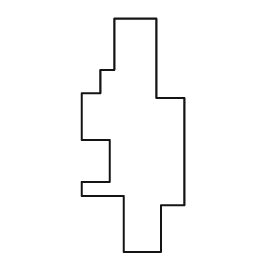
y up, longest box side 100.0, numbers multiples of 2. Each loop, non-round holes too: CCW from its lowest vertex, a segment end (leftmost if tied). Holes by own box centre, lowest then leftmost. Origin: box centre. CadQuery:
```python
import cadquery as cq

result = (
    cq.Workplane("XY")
    .moveTo(-4.0, -50.0)
    .lineTo(12.0, -50.0)
    .lineTo(12.0, -30.0)
    .lineTo(22.0, -30.0)
    .lineTo(22.0, 16.0)
    .lineTo(10.0, 16.0)
    .lineTo(10.0, 50.0)
    .lineTo(-8.0, 50.0)
    .lineTo(-8.0, 28.0)
    .lineTo(-14.0, 28.0)
    .lineTo(-14.0, 18.0)
    .lineTo(-22.0, 18.0)
    .lineTo(-22.0, -2.0)
    .lineTo(-10.0, -2.0)
    .lineTo(-10.0, -20.0)
    .lineTo(-22.0, -20.0)
    .lineTo(-22.0, -26.0)
    .lineTo(-4.0, -26.0)
    .close()
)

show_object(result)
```